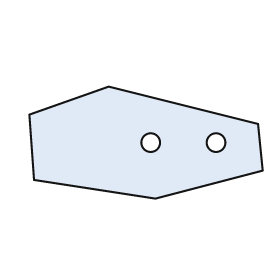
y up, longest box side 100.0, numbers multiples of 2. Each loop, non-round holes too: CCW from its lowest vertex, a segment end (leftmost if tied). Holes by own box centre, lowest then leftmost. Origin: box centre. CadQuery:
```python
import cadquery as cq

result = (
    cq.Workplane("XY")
    .moveTo(4.0, -24.0)
    .lineTo(50.0, -12.0)
    .lineTo(48.0, 8.0)
    .lineTo(-16.0, 24.0)
    .lineTo(-50.0, 12.0)
    .lineTo(-48.0, -16.0)
    .close()
    .moveTo(2.0, 0.0)
    .circle(4.0)
    .moveTo(30.0, 0.0)
    .circle(4.0)
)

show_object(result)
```